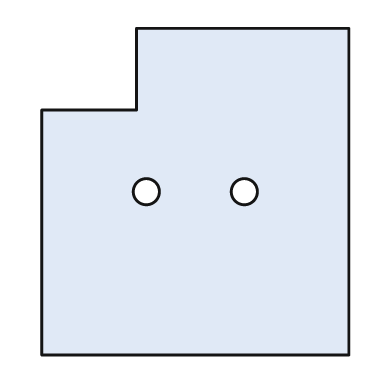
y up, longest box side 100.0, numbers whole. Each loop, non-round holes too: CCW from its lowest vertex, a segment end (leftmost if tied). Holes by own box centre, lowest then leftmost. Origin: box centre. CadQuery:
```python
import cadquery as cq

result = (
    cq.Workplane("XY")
    .moveTo(-47.0, -50.0)
    .lineTo(47.0, -50.0)
    .lineTo(47.0, 50.0)
    .lineTo(-18.0, 50.0)
    .lineTo(-18.0, 25.0)
    .lineTo(-47.0, 25.0)
    .close()
    .moveTo(-15.0, 0.0)
    .circle(4.0)
    .moveTo(15.0, 0.0)
    .circle(4.0)
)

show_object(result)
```